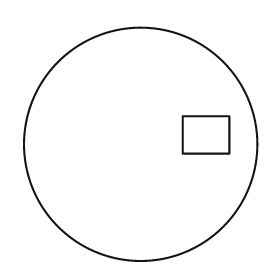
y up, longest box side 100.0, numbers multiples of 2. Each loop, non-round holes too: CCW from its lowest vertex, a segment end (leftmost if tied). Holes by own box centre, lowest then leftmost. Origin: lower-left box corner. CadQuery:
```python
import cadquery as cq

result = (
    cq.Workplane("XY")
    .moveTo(50.0, 50.0)
    .circle(50.0)
    .moveTo(68.0, 46.0)
    .lineTo(88.0, 46.0)
    .lineTo(88.0, 62.0)
    .lineTo(68.0, 62.0)
    .close()
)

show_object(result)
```